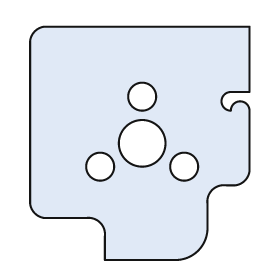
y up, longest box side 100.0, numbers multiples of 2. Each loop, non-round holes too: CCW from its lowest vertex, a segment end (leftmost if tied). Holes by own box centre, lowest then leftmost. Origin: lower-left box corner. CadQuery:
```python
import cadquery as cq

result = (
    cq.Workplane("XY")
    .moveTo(32.0, 0.0)
    .lineTo(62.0, 0.0)
    .threePointArc((72.0, 4.0), (76.0, 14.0))
    .lineTo(76.0, 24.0)
    .threePointArc((78.0, 30.0), (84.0, 32.0))
    .lineTo(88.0, 32.0)
    .threePointArc((92.0, 34.0), (94.0, 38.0))
    .lineTo(94.0, 64.0)
    .threePointArc((90.0, 68.0), (86.0, 64.0))
    .threePointArc((82.0, 68.0), (86.0, 72.0))
    .lineTo(94.0, 72.0)
    .lineTo(94.0, 100.0)
    .lineTo(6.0, 100.0)
    .threePointArc((2.0, 98.0), (0.0, 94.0))
    .lineTo(0.0, 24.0)
    .threePointArc((2.0, 20.0), (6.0, 18.0))
    .lineTo(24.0, 18.0)
    .threePointArc((30.0, 16.0), (32.0, 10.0))
    .close()
    .moveTo(30.0, 40.0)
    .circle(6.0)
    .moveTo(66.0, 40.0)
    .circle(6.0)
    .moveTo(48.0, 50.0)
    .circle(10.0)
    .moveTo(48.0, 70.0)
    .circle(6.0)
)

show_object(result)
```